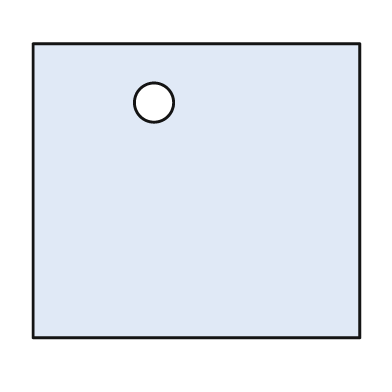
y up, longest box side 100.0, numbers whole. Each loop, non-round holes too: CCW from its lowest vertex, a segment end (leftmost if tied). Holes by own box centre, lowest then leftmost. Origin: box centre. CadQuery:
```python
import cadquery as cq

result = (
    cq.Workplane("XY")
    .moveTo(-50.0, -45.0)
    .lineTo(50.0, -45.0)
    .lineTo(50.0, 45.0)
    .lineTo(-50.0, 45.0)
    .close()
    .moveTo(-13.0, 27.0)
    .circle(6.0)
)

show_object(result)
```